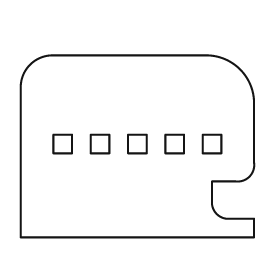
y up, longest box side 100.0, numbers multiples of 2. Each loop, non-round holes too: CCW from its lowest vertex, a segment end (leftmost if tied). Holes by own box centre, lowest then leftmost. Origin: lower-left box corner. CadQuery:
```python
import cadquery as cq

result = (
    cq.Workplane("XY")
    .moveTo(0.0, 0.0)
    .lineTo(100.0, 0.0)
    .lineTo(100.0, 8.0)
    .lineTo(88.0, 8.0)
    .threePointArc((84.0, 10.0), (82.0, 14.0))
    .lineTo(82.0, 24.0)
    .lineTo(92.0, 24.0)
    .threePointArc((98.0, 26.0), (100.0, 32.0))
    .lineTo(100.0, 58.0)
    .threePointArc((94.0, 72.0), (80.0, 78.0))
    .lineTo(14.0, 78.0)
    .threePointArc((4.0, 74.0), (0.0, 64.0))
    .close()
    .moveTo(14.0, 36.0)
    .lineTo(22.0, 36.0)
    .lineTo(22.0, 44.0)
    .lineTo(14.0, 44.0)
    .close()
    .moveTo(30.0, 36.0)
    .lineTo(38.0, 36.0)
    .lineTo(38.0, 44.0)
    .lineTo(30.0, 44.0)
    .close()
    .moveTo(46.0, 36.0)
    .lineTo(54.0, 36.0)
    .lineTo(54.0, 44.0)
    .lineTo(46.0, 44.0)
    .close()
    .moveTo(62.0, 36.0)
    .lineTo(70.0, 36.0)
    .lineTo(70.0, 44.0)
    .lineTo(62.0, 44.0)
    .close()
    .moveTo(78.0, 36.0)
    .lineTo(86.0, 36.0)
    .lineTo(86.0, 44.0)
    .lineTo(78.0, 44.0)
    .close()
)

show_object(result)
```